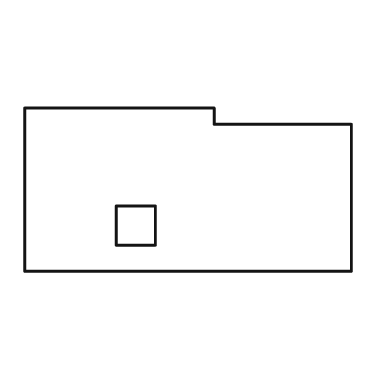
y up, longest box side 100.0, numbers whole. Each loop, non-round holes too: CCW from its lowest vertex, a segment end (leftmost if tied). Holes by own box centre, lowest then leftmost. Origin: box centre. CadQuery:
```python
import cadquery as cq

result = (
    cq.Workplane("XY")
    .moveTo(-50.0, -25.0)
    .lineTo(50.0, -25.0)
    .lineTo(50.0, 20.0)
    .lineTo(8.0, 20.0)
    .lineTo(8.0, 25.0)
    .lineTo(-50.0, 25.0)
    .close()
    .moveTo(-22.0, -17.0)
    .lineTo(-10.0, -17.0)
    .lineTo(-10.0, -5.0)
    .lineTo(-22.0, -5.0)
    .close()
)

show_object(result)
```